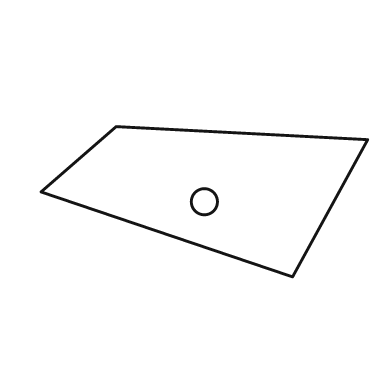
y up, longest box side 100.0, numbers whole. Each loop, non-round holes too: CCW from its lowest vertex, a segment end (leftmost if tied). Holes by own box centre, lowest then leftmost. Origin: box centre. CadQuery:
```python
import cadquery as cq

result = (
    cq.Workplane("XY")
    .moveTo(27.0, -23.0)
    .lineTo(50.0, 19.0)
    .lineTo(-27.0, 23.0)
    .lineTo(-50.0, 3.0)
    .close()
    .moveTo(0.0, 0.0)
    .circle(4.0)
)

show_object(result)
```